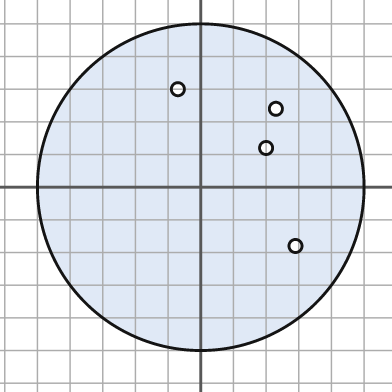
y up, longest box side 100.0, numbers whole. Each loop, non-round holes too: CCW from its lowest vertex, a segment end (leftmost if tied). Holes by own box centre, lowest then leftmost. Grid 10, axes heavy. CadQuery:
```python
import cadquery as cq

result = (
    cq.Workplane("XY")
    .moveTo(0.0, 0.0)
    .circle(50.0)
    .moveTo(29.0, -18.0)
    .circle(2.0)
    .moveTo(20.0, 12.0)
    .circle(2.0)
    .moveTo(23.0, 24.0)
    .circle(2.0)
    .moveTo(-7.0, 30.0)
    .circle(2.0)
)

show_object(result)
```